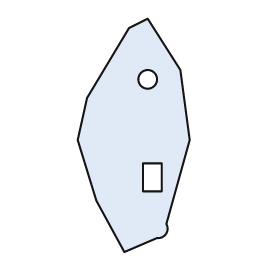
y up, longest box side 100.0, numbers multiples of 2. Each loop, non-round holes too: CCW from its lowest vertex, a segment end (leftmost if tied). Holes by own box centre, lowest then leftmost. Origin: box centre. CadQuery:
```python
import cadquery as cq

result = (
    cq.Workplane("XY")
    .moveTo(-4.0, -50.0)
    .lineTo(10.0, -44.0)
    .threePointArc((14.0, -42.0), (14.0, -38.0))
    .lineTo(24.0, -2.0)
    .lineTo(20.0, 28.0)
    .lineTo(6.0, 50.0)
    .lineTo(-2.0, 46.0)
    .lineTo(-20.0, 16.0)
    .lineTo(-24.0, -2.0)
    .lineTo(-16.0, -28.0)
    .close()
    .moveTo(4.0, -24.0)
    .lineTo(12.0, -24.0)
    .lineTo(12.0, -12.0)
    .lineTo(4.0, -12.0)
    .close()
    .moveTo(6.0, 24.0)
    .circle(4.0)
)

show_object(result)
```